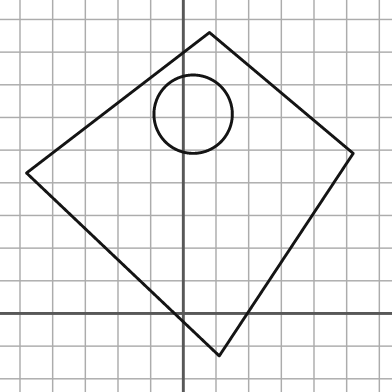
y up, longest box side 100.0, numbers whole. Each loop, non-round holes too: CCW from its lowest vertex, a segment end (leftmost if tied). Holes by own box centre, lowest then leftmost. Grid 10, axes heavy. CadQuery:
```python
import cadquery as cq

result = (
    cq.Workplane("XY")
    .moveTo(11.0, -13.0)
    .lineTo(52.0, 49.0)
    .lineTo(8.0, 86.0)
    .lineTo(-48.0, 43.0)
    .close()
    .moveTo(3.0, 61.0)
    .circle(12.0)
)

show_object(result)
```